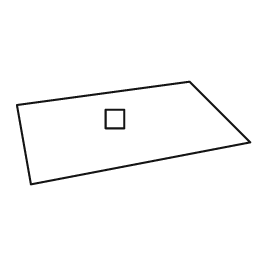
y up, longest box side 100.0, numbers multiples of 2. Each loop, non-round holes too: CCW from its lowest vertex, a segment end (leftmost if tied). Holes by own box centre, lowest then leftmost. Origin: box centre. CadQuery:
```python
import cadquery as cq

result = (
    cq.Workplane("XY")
    .moveTo(-44.0, -22.0)
    .lineTo(50.0, -4.0)
    .lineTo(24.0, 22.0)
    .lineTo(-50.0, 12.0)
    .close()
    .moveTo(-12.0, 2.0)
    .lineTo(-4.0, 2.0)
    .lineTo(-4.0, 10.0)
    .lineTo(-12.0, 10.0)
    .close()
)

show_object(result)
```